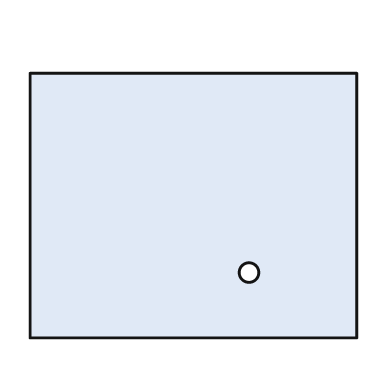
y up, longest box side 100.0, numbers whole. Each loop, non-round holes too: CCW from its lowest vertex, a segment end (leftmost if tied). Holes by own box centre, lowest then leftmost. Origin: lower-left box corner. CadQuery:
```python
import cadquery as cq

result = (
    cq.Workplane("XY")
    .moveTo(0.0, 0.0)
    .lineTo(100.0, 0.0)
    .lineTo(100.0, 81.0)
    .lineTo(0.0, 81.0)
    .close()
    .moveTo(67.0, 20.0)
    .circle(3.0)
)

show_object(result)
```